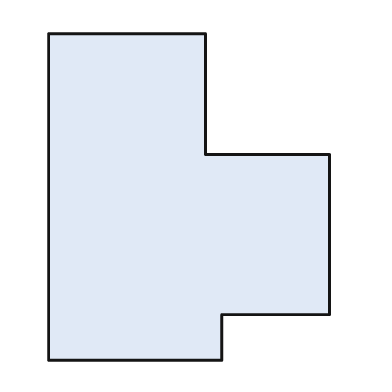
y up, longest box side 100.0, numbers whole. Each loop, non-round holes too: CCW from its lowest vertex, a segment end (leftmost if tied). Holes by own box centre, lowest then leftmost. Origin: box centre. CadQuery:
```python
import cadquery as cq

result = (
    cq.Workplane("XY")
    .moveTo(-43.0, -50.0)
    .lineTo(10.0, -50.0)
    .lineTo(10.0, -36.0)
    .lineTo(43.0, -36.0)
    .lineTo(43.0, 13.0)
    .lineTo(5.0, 13.0)
    .lineTo(5.0, 50.0)
    .lineTo(-43.0, 50.0)
    .close()
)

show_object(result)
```